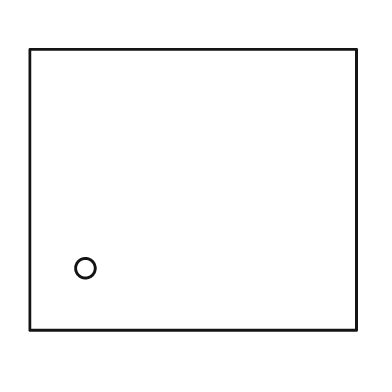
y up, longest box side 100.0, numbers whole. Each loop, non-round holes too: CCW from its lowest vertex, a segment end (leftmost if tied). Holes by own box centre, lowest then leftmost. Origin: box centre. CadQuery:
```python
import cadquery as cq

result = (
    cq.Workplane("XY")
    .moveTo(-50.0, -43.0)
    .lineTo(50.0, -43.0)
    .lineTo(50.0, 43.0)
    .lineTo(-50.0, 43.0)
    .close()
    .moveTo(-33.0, -24.0)
    .circle(3.0)
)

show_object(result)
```